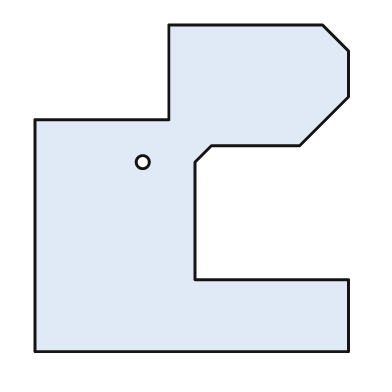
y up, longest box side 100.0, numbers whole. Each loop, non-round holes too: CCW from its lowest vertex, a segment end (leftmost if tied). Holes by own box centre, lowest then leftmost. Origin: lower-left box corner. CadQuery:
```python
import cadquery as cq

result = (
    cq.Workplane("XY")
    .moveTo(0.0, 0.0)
    .lineTo(96.0, 0.0)
    .lineTo(96.0, 22.0)
    .lineTo(49.0, 22.0)
    .lineTo(49.0, 58.0)
    .lineTo(54.0, 63.0)
    .lineTo(81.0, 63.0)
    .lineTo(96.0, 78.0)
    .lineTo(96.0, 92.0)
    .lineTo(88.0, 100.0)
    .lineTo(41.0, 100.0)
    .lineTo(41.0, 71.0)
    .lineTo(0.0, 71.0)
    .close()
    .moveTo(33.0, 58.0)
    .circle(2.0)
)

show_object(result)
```